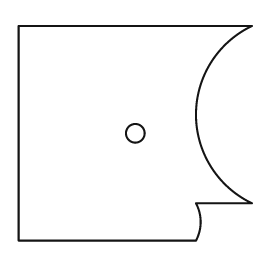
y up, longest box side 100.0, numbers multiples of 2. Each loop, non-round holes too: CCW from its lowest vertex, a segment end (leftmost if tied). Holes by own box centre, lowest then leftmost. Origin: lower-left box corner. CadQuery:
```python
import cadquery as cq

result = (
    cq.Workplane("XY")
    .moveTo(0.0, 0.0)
    .lineTo(76.0, 0.0)
    .threePointArc((78.0, 8.0), (76.0, 16.0))
    .lineTo(100.0, 16.0)
    .threePointArc((76.0, 54.0), (100.0, 92.0))
    .lineTo(0.0, 92.0)
    .close()
    .moveTo(50.0, 46.0)
    .circle(4.0)
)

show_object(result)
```